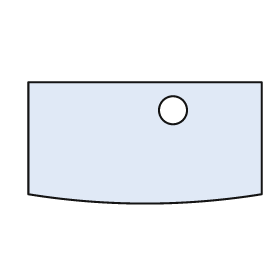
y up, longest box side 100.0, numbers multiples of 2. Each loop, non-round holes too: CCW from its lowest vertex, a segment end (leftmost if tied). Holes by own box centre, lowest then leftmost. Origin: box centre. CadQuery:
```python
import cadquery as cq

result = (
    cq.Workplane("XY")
    .moveTo(-50.0, -22.0)
    .threePointArc((0.0, -26.0), (50.0, -22.0))
    .lineTo(50.0, 26.0)
    .lineTo(-50.0, 26.0)
    .close()
    .moveTo(12.0, 14.0)
    .circle(6.0)
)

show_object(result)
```